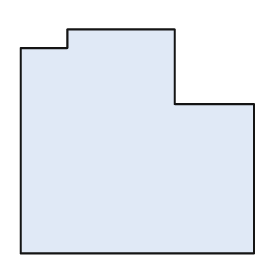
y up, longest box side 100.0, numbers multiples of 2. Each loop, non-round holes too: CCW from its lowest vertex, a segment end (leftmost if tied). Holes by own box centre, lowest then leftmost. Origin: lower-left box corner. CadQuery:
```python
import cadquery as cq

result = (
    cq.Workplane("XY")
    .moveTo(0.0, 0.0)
    .lineTo(100.0, 0.0)
    .lineTo(100.0, 64.0)
    .lineTo(66.0, 64.0)
    .lineTo(66.0, 96.0)
    .lineTo(20.0, 96.0)
    .lineTo(20.0, 88.0)
    .lineTo(0.0, 88.0)
    .close()
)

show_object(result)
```